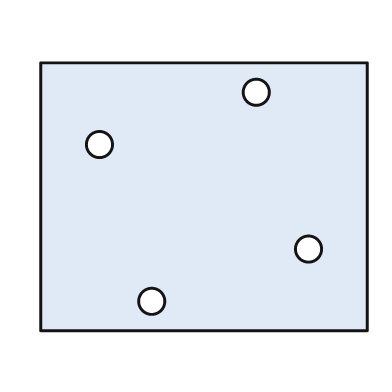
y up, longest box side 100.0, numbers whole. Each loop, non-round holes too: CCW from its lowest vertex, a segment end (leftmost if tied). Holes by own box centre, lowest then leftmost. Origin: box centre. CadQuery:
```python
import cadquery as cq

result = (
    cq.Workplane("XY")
    .moveTo(-50.0, -41.0)
    .lineTo(50.0, -41.0)
    .lineTo(50.0, 41.0)
    .lineTo(-50.0, 41.0)
    .close()
    .moveTo(-16.0, -32.0)
    .circle(4.0)
    .moveTo(32.0, -16.0)
    .circle(4.0)
    .moveTo(-32.0, 16.0)
    .circle(4.0)
    .moveTo(16.0, 32.0)
    .circle(4.0)
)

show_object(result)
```